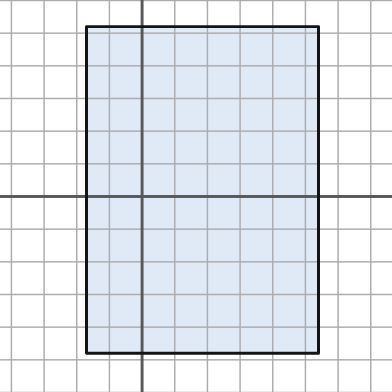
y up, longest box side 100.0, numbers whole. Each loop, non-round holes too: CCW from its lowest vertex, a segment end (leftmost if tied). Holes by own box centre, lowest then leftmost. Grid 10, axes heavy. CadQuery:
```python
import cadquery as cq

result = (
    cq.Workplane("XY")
    .moveTo(-17.0, -48.0)
    .lineTo(54.0, -48.0)
    .lineTo(54.0, 52.0)
    .lineTo(-17.0, 52.0)
    .close()
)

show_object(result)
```